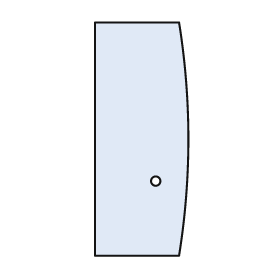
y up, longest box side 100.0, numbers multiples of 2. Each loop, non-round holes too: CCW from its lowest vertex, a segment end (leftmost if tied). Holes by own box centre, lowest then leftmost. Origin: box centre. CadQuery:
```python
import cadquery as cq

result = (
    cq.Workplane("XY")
    .moveTo(-20.0, -50.0)
    .lineTo(16.0, -50.0)
    .threePointArc((20.0, 0.0), (16.0, 50.0))
    .lineTo(-20.0, 50.0)
    .close()
    .moveTo(6.0, -18.0)
    .circle(2.0)
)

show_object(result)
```